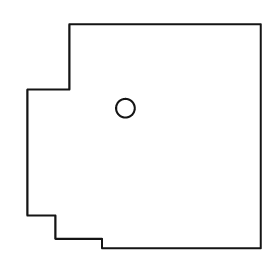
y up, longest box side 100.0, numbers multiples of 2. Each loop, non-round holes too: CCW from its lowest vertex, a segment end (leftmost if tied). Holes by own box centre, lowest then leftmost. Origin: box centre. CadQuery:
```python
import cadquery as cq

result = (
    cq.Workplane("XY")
    .moveTo(-18.0, -48.0)
    .lineTo(50.0, -48.0)
    .lineTo(50.0, 48.0)
    .lineTo(-32.0, 48.0)
    .lineTo(-32.0, 20.0)
    .lineTo(-50.0, 20.0)
    .lineTo(-50.0, -34.0)
    .lineTo(-38.0, -34.0)
    .lineTo(-38.0, -44.0)
    .lineTo(-18.0, -44.0)
    .close()
    .moveTo(-8.0, 12.0)
    .circle(4.0)
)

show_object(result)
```